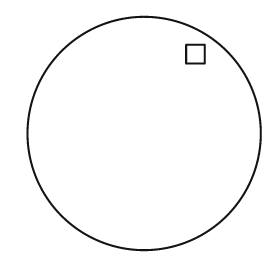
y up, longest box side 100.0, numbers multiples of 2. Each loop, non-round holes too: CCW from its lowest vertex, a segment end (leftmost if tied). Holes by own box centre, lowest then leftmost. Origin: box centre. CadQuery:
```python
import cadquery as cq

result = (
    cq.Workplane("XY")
    .moveTo(0.0, 0.0)
    .circle(50.0)
    .moveTo(18.0, 30.0)
    .lineTo(26.0, 30.0)
    .lineTo(26.0, 38.0)
    .lineTo(18.0, 38.0)
    .close()
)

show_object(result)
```